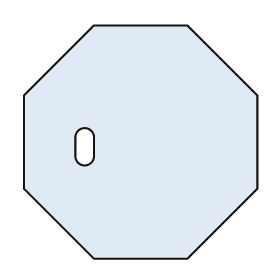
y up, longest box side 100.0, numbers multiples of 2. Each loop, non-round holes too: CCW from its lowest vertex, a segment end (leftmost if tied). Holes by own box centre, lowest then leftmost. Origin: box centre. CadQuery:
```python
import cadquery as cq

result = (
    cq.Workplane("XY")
    .moveTo(-20.0, -50.0)
    .lineTo(20.0, -50.0)
    .lineTo(50.0, -20.0)
    .lineTo(50.0, 20.0)
    .lineTo(20.0, 50.0)
    .lineTo(-20.0, 50.0)
    .lineTo(-50.0, 20.0)
    .lineTo(-50.0, -20.0)
    .close()
    .moveTo(-28.0, -6.0)
    .threePointArc((-24.0, -10.0), (-20.0, -6.0))
    .lineTo(-20.0, 2.0)
    .threePointArc((-24.0, 6.0), (-28.0, 2.0))
    .close()
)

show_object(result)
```